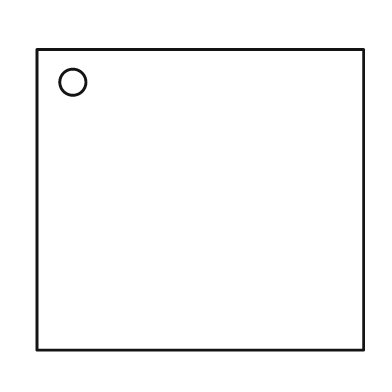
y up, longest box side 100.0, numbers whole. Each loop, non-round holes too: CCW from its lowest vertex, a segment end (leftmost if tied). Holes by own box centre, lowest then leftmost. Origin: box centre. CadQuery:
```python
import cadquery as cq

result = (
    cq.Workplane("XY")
    .moveTo(-50.0, -46.0)
    .lineTo(50.0, -46.0)
    .lineTo(50.0, 46.0)
    .lineTo(-50.0, 46.0)
    .close()
    .moveTo(-39.0, 36.0)
    .circle(4.0)
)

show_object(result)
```